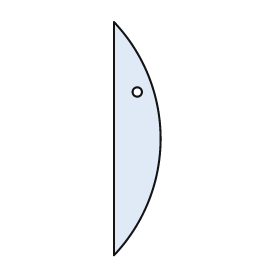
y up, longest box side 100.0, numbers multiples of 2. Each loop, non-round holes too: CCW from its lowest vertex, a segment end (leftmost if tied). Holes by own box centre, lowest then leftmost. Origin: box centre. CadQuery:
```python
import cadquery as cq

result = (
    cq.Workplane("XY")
    .moveTo(-10.0, -50.0)
    .threePointArc((10.0, 0.0), (-10.0, 50.0))
    .close()
    .moveTo(0.0, 20.0)
    .circle(2.0)
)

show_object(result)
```